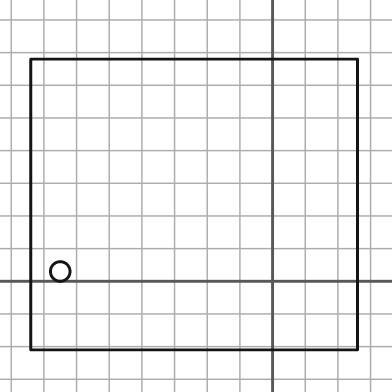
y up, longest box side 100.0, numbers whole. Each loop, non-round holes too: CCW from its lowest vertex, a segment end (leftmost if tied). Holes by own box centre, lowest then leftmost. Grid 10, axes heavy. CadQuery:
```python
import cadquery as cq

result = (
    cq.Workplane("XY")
    .moveTo(-74.0, -21.0)
    .lineTo(26.0, -21.0)
    .lineTo(26.0, 68.0)
    .lineTo(-74.0, 68.0)
    .close()
    .moveTo(-65.0, 3.0)
    .circle(3.0)
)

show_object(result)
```